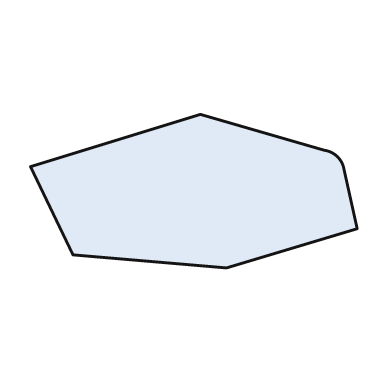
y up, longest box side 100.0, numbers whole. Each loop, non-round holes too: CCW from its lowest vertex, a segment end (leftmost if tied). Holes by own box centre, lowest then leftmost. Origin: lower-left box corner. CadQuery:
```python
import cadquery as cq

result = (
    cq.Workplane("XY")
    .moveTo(60.0, 0.0)
    .lineTo(100.0, 12.0)
    .lineTo(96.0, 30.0)
    .threePointArc((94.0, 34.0), (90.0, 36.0))
    .lineTo(52.0, 47.0)
    .lineTo(0.0, 31.0)
    .lineTo(13.0, 4.0)
    .close()
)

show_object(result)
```